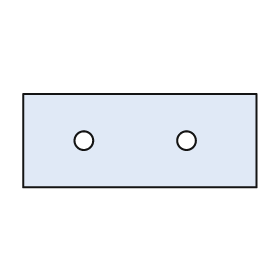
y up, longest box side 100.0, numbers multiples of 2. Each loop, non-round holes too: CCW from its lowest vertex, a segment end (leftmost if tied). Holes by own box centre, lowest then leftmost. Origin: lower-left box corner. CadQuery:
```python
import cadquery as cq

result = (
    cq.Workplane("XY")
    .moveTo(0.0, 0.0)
    .lineTo(100.0, 0.0)
    .lineTo(100.0, 40.0)
    .lineTo(0.0, 40.0)
    .close()
    .moveTo(26.0, 20.0)
    .circle(4.0)
    .moveTo(70.0, 20.0)
    .circle(4.0)
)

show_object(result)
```